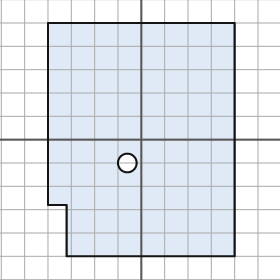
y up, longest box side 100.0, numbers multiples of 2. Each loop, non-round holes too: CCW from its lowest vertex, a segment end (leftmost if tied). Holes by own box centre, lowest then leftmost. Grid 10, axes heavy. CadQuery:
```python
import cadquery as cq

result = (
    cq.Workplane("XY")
    .moveTo(-32.0, -50.0)
    .lineTo(40.0, -50.0)
    .lineTo(40.0, 50.0)
    .lineTo(-40.0, 50.0)
    .lineTo(-40.0, -28.0)
    .lineTo(-32.0, -28.0)
    .close()
    .moveTo(-6.0, -10.0)
    .circle(4.0)
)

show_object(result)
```